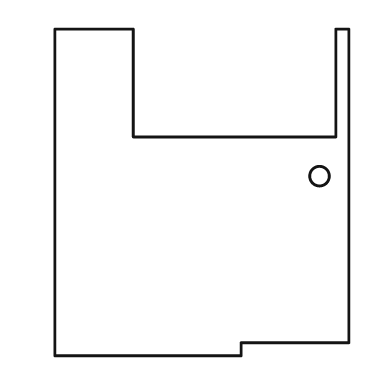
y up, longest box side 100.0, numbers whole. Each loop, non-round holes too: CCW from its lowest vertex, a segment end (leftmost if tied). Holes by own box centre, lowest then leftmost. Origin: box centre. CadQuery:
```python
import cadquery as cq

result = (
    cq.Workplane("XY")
    .moveTo(-45.0, -50.0)
    .lineTo(12.0, -50.0)
    .lineTo(12.0, -46.0)
    .lineTo(45.0, -46.0)
    .lineTo(45.0, 50.0)
    .lineTo(41.0, 50.0)
    .lineTo(41.0, 17.0)
    .lineTo(-21.0, 17.0)
    .lineTo(-21.0, 50.0)
    .lineTo(-45.0, 50.0)
    .close()
    .moveTo(36.0, 5.0)
    .circle(3.0)
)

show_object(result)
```